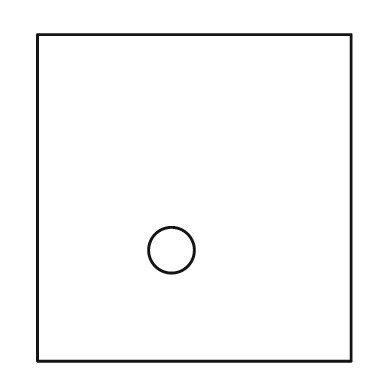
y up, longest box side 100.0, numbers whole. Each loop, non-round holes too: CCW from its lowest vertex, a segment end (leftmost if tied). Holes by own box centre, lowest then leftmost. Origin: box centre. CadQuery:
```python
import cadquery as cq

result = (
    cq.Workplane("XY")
    .moveTo(-48.0, -50.0)
    .lineTo(48.0, -50.0)
    .lineTo(48.0, 50.0)
    .lineTo(-48.0, 50.0)
    .close()
    .moveTo(-7.0, -16.0)
    .circle(7.0)
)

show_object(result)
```